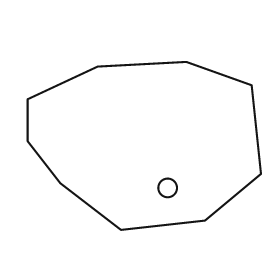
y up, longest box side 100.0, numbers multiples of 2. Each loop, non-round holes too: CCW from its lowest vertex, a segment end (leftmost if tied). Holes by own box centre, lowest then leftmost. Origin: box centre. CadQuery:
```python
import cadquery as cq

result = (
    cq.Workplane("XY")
    .moveTo(-10.0, -36.0)
    .lineTo(26.0, -32.0)
    .lineTo(50.0, -12.0)
    .lineTo(46.0, 26.0)
    .lineTo(18.0, 36.0)
    .lineTo(-20.0, 34.0)
    .lineTo(-50.0, 20.0)
    .lineTo(-50.0, 2.0)
    .lineTo(-36.0, -16.0)
    .close()
    .moveTo(10.0, -18.0)
    .circle(4.0)
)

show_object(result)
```